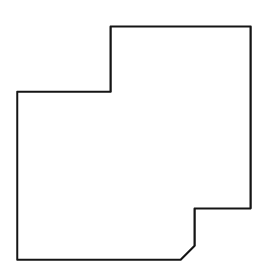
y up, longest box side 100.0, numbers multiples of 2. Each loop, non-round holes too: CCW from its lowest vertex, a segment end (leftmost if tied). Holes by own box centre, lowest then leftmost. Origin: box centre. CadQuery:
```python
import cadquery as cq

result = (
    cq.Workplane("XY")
    .moveTo(-50.0, -50.0)
    .lineTo(20.0, -50.0)
    .lineTo(26.0, -44.0)
    .lineTo(26.0, -28.0)
    .lineTo(50.0, -28.0)
    .lineTo(50.0, 50.0)
    .lineTo(-10.0, 50.0)
    .lineTo(-10.0, 22.0)
    .lineTo(-50.0, 22.0)
    .close()
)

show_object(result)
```